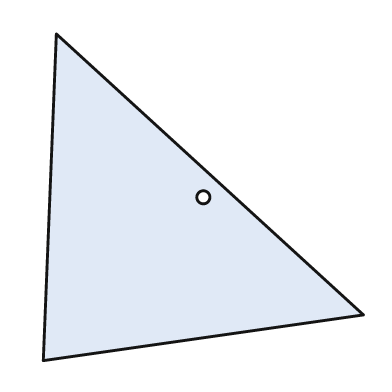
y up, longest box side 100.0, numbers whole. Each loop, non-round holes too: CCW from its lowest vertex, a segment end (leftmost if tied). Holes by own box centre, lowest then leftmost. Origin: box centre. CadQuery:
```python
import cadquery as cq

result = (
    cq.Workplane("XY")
    .moveTo(-49.0, -50.0)
    .lineTo(49.0, -36.0)
    .lineTo(-45.0, 50.0)
    .close()
    .moveTo(0.0, 0.0)
    .circle(2.0)
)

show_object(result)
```